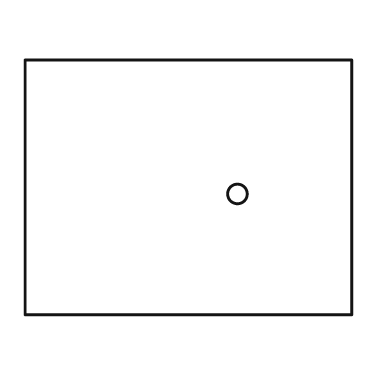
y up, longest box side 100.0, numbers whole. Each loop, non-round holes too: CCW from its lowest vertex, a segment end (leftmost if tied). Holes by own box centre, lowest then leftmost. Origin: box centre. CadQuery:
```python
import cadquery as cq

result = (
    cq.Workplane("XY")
    .moveTo(-50.0, -39.0)
    .lineTo(50.0, -39.0)
    .lineTo(50.0, 39.0)
    .lineTo(-50.0, 39.0)
    .close()
    .moveTo(15.0, -2.0)
    .circle(3.0)
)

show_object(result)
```